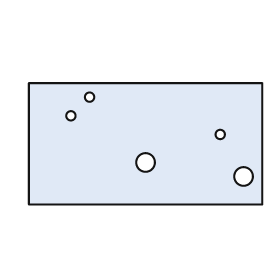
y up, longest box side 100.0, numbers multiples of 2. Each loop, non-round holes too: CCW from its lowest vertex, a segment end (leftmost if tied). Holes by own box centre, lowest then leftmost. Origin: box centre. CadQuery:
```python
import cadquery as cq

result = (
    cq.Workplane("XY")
    .moveTo(-50.0, -26.0)
    .lineTo(50.0, -26.0)
    .lineTo(50.0, 26.0)
    .lineTo(-50.0, 26.0)
    .close()
    .moveTo(42.0, -14.0)
    .circle(4.0)
    .moveTo(0.0, -8.0)
    .circle(4.0)
    .moveTo(32.0, 4.0)
    .circle(2.0)
    .moveTo(-32.0, 12.0)
    .circle(2.0)
    .moveTo(-24.0, 20.0)
    .circle(2.0)
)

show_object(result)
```